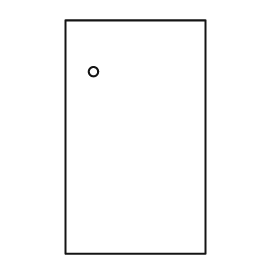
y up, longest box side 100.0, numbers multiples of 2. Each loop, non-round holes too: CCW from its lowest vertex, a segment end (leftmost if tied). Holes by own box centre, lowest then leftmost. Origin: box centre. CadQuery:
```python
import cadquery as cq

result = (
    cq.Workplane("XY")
    .moveTo(-30.0, -50.0)
    .lineTo(30.0, -50.0)
    .lineTo(30.0, 50.0)
    .lineTo(-30.0, 50.0)
    .close()
    .moveTo(-18.0, 28.0)
    .circle(2.0)
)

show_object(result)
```